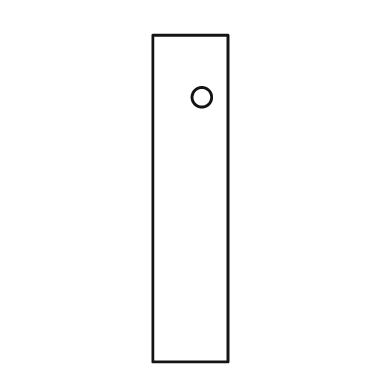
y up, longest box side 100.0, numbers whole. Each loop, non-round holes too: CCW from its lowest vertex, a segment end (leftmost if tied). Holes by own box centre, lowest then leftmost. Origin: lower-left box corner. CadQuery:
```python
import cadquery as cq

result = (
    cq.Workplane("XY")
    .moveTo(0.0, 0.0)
    .lineTo(23.0, 0.0)
    .lineTo(23.0, 100.0)
    .lineTo(0.0, 100.0)
    .close()
    .moveTo(15.0, 81.0)
    .circle(3.0)
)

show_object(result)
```